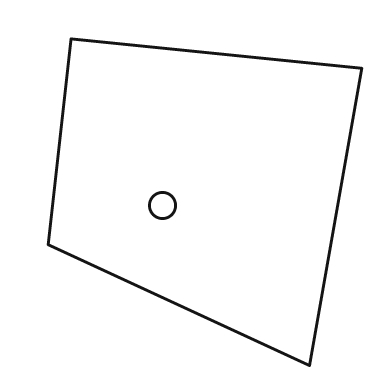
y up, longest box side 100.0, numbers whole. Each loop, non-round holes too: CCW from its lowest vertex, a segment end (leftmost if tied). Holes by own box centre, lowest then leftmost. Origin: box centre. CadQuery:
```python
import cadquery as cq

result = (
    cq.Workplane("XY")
    .moveTo(32.0, -50.0)
    .lineTo(48.0, 41.0)
    .lineTo(-41.0, 50.0)
    .lineTo(-48.0, -13.0)
    .close()
    .moveTo(-13.0, -1.0)
    .circle(4.0)
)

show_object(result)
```